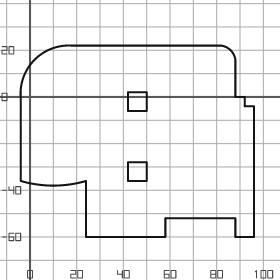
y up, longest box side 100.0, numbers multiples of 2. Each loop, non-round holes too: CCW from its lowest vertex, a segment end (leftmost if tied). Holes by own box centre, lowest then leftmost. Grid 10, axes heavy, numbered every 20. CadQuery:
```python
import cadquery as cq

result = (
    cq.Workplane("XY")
    .moveTo(24.0, -60.0)
    .lineTo(58.0, -60.0)
    .lineTo(58.0, -52.0)
    .lineTo(88.0, -52.0)
    .lineTo(88.0, -60.0)
    .lineTo(96.0, -60.0)
    .lineTo(96.0, -4.0)
    .lineTo(92.0, -4.0)
    .lineTo(92.0, 0.0)
    .lineTo(88.0, 0.0)
    .lineTo(88.0, 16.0)
    .threePointArc((86.0, 20.0), (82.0, 22.0))
    .lineTo(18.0, 22.0)
    .threePointArc((2.0, 16.0), (-4.0, 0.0))
    .lineTo(-4.0, -36.0)
    .threePointArc((10.0, -38.0), (24.0, -36.0))
    .close()
    .moveTo(42.0, -36.0)
    .lineTo(50.0, -36.0)
    .lineTo(50.0, -28.0)
    .lineTo(42.0, -28.0)
    .close()
    .moveTo(42.0, -6.0)
    .lineTo(50.0, -6.0)
    .lineTo(50.0, 2.0)
    .lineTo(42.0, 2.0)
    .close()
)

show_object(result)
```